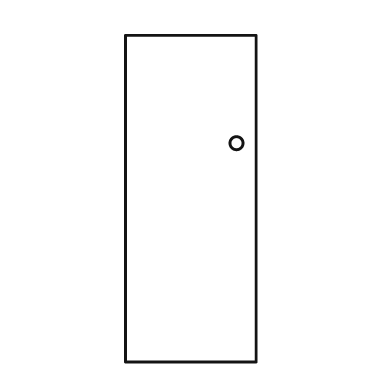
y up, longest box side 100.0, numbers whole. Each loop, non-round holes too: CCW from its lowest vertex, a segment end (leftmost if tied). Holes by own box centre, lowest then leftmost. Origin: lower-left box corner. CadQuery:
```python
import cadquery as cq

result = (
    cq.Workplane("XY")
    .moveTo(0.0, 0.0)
    .lineTo(40.0, 0.0)
    .lineTo(40.0, 100.0)
    .lineTo(0.0, 100.0)
    .close()
    .moveTo(34.0, 67.0)
    .circle(2.0)
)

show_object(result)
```